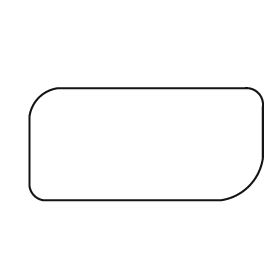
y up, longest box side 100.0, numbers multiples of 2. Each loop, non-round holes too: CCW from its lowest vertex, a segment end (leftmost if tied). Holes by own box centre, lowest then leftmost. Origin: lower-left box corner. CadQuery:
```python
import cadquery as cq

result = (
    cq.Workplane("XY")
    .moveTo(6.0, 0.0)
    .lineTo(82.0, 0.0)
    .threePointArc((94.0, 6.0), (100.0, 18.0))
    .lineTo(100.0, 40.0)
    .threePointArc((98.0, 46.0), (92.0, 48.0))
    .lineTo(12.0, 48.0)
    .threePointArc((4.0, 44.0), (0.0, 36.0))
    .lineTo(0.0, 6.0)
    .threePointArc((2.0, 2.0), (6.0, 0.0))
    .close()
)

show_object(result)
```